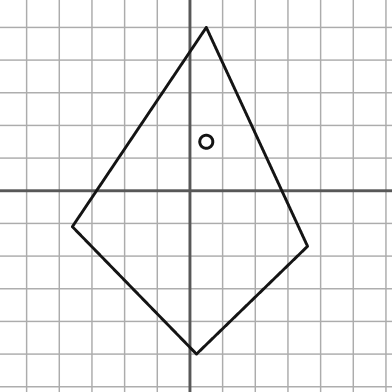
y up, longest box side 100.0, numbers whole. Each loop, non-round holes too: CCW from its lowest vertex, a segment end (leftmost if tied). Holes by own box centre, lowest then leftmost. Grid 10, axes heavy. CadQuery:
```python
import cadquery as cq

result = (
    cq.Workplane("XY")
    .moveTo(2.0, -50.0)
    .lineTo(36.0, -17.0)
    .lineTo(5.0, 50.0)
    .lineTo(-36.0, -11.0)
    .close()
    .moveTo(5.0, 15.0)
    .circle(2.0)
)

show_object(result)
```